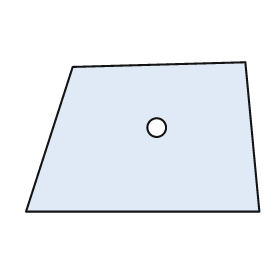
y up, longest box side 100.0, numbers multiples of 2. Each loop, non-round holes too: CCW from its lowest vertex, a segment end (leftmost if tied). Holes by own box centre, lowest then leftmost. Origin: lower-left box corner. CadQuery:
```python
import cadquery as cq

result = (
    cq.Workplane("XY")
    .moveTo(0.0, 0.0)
    .lineTo(100.0, 0.0)
    .lineTo(94.0, 64.0)
    .lineTo(20.0, 62.0)
    .close()
    .moveTo(56.0, 36.0)
    .circle(4.0)
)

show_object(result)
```